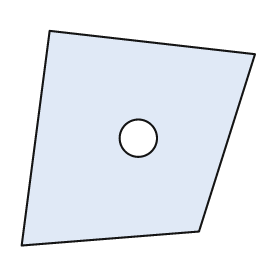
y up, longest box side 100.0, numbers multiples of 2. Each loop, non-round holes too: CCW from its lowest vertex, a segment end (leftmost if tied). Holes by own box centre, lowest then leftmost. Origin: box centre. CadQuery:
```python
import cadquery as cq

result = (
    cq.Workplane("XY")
    .moveTo(-50.0, -46.0)
    .lineTo(26.0, -40.0)
    .lineTo(50.0, 36.0)
    .lineTo(-38.0, 46.0)
    .close()
    .moveTo(0.0, 0.0)
    .circle(8.0)
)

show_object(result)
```